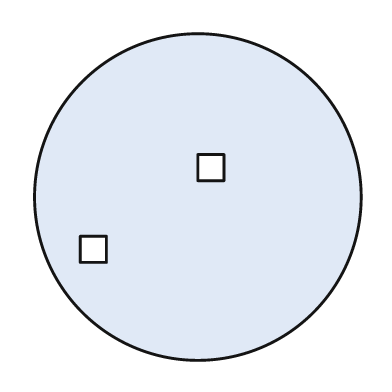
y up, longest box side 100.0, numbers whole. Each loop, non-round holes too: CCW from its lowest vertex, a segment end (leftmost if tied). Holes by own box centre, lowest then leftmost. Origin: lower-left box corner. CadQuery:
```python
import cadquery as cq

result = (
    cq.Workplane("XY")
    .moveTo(50.0, 50.0)
    .circle(50.0)
    .moveTo(14.0, 30.0)
    .lineTo(22.0, 30.0)
    .lineTo(22.0, 38.0)
    .lineTo(14.0, 38.0)
    .close()
    .moveTo(50.0, 55.0)
    .lineTo(58.0, 55.0)
    .lineTo(58.0, 63.0)
    .lineTo(50.0, 63.0)
    .close()
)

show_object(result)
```